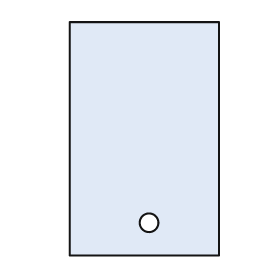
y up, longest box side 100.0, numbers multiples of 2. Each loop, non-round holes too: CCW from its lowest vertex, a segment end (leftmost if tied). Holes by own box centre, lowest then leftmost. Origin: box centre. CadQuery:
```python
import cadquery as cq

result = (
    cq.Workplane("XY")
    .moveTo(-32.0, -50.0)
    .lineTo(32.0, -50.0)
    .lineTo(32.0, 50.0)
    .lineTo(-32.0, 50.0)
    .close()
    .moveTo(2.0, -36.0)
    .circle(4.0)
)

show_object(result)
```